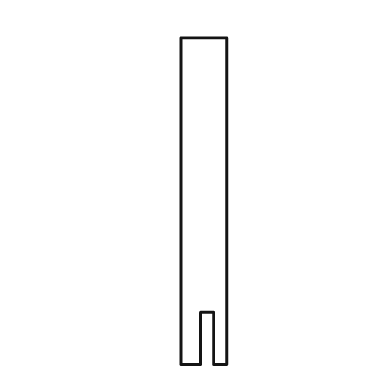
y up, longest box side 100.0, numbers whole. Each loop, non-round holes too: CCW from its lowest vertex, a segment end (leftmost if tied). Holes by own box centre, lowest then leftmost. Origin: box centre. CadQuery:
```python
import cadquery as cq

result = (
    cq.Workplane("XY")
    .moveTo(-7.0, -50.0)
    .lineTo(-1.0, -50.0)
    .lineTo(-1.0, -34.0)
    .lineTo(3.0, -34.0)
    .lineTo(3.0, -50.0)
    .lineTo(7.0, -50.0)
    .lineTo(7.0, 50.0)
    .lineTo(-7.0, 50.0)
    .close()
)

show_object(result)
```